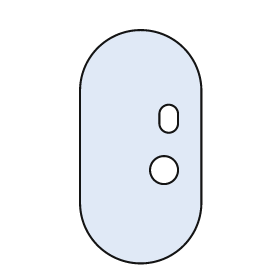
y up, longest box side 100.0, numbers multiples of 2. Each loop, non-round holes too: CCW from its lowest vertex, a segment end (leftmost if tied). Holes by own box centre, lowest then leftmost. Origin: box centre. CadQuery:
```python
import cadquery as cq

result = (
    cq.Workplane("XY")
    .moveTo(-26.0, -24.0)
    .threePointArc((0.0, -50.0), (26.0, -24.0))
    .lineTo(26.0, 24.0)
    .threePointArc((0.0, 50.0), (-26.0, 24.0))
    .close()
    .moveTo(10.0, -10.0)
    .circle(6.0)
    .moveTo(8.0, 10.0)
    .threePointArc((12.0, 6.0), (16.0, 10.0))
    .lineTo(16.0, 14.0)
    .threePointArc((12.0, 18.0), (8.0, 14.0))
    .close()
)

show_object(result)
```